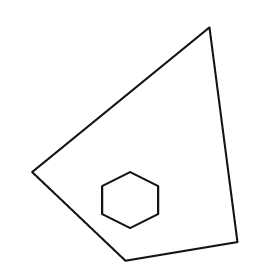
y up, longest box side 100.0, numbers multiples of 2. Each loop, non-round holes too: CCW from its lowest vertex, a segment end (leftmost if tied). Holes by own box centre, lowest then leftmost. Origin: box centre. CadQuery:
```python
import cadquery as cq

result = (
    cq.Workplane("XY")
    .moveTo(-4.0, -50.0)
    .lineTo(44.0, -42.0)
    .lineTo(32.0, 50.0)
    .lineTo(-44.0, -12.0)
    .close()
    .moveTo(-2.0, -36.0)
    .lineTo(10.0, -30.0)
    .lineTo(10.0, -18.0)
    .lineTo(-2.0, -12.0)
    .lineTo(-14.0, -18.0)
    .lineTo(-14.0, -30.0)
    .close()
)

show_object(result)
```